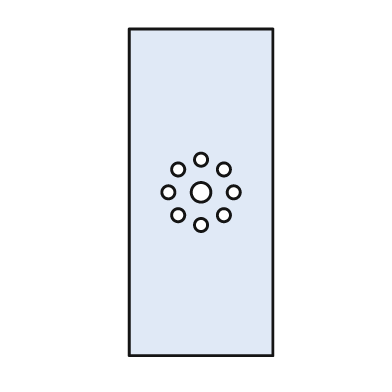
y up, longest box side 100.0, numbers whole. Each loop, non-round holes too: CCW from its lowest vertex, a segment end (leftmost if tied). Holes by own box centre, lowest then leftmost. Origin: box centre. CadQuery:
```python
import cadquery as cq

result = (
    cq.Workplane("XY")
    .moveTo(-22.0, -50.0)
    .lineTo(22.0, -50.0)
    .lineTo(22.0, 50.0)
    .lineTo(-22.0, 50.0)
    .close()
    .moveTo(0.0, -10.0)
    .circle(2.0)
    .moveTo(-7.0, -7.0)
    .circle(2.0)
    .moveTo(7.0, -7.0)
    .circle(2.0)
    .moveTo(-10.0, 0.0)
    .circle(2.0)
    .moveTo(0.0, 0.0)
    .circle(3.0)
    .moveTo(10.0, 0.0)
    .circle(2.0)
    .moveTo(-7.0, 7.0)
    .circle(2.0)
    .moveTo(7.0, 7.0)
    .circle(2.0)
    .moveTo(0.0, 10.0)
    .circle(2.0)
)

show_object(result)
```